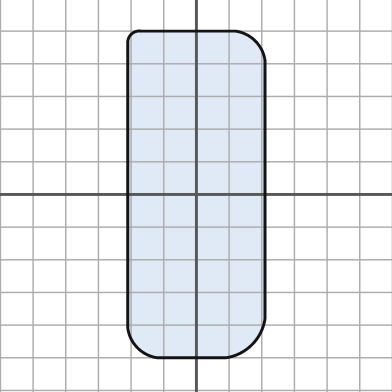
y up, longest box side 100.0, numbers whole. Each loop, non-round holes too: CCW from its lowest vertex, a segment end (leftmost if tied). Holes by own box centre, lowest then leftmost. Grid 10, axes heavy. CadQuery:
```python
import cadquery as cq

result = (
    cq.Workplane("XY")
    .moveTo(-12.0, -50.0)
    .lineTo(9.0, -50.0)
    .threePointArc((17.0, -46.0), (21.0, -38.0))
    .lineTo(21.0, 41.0)
    .threePointArc((18.0, 47.0), (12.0, 50.0))
    .lineTo(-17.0, 50.0)
    .threePointArc((-20.0, 49.0), (-21.0, 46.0))
    .lineTo(-21.0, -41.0)
    .threePointArc((-18.0, -47.0), (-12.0, -50.0))
    .close()
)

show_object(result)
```